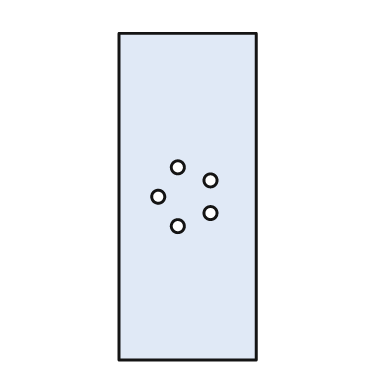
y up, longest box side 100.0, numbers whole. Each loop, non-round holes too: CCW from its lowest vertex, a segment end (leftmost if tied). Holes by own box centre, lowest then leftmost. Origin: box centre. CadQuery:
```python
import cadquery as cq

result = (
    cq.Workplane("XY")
    .moveTo(-21.0, -50.0)
    .lineTo(21.0, -50.0)
    .lineTo(21.0, 50.0)
    .lineTo(-21.0, 50.0)
    .close()
    .moveTo(-3.0, -9.0)
    .circle(2.0)
    .moveTo(7.0, -5.0)
    .circle(2.0)
    .moveTo(-9.0, 0.0)
    .circle(2.0)
    .moveTo(7.0, 5.0)
    .circle(2.0)
    .moveTo(-3.0, 9.0)
    .circle(2.0)
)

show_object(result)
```